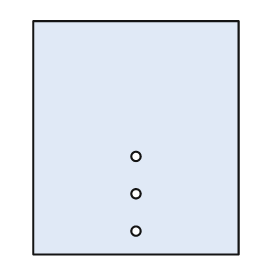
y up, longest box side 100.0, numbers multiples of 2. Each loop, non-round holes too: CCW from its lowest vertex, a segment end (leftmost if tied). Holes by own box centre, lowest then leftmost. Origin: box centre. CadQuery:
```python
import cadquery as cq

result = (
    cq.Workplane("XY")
    .moveTo(-44.0, -50.0)
    .lineTo(44.0, -50.0)
    .lineTo(44.0, 50.0)
    .lineTo(-44.0, 50.0)
    .close()
    .moveTo(0.0, -40.0)
    .circle(2.0)
    .moveTo(0.0, -24.0)
    .circle(2.0)
    .moveTo(0.0, -8.0)
    .circle(2.0)
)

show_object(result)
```